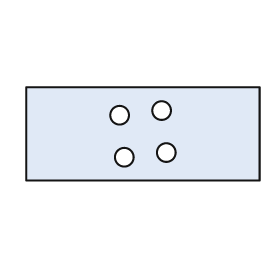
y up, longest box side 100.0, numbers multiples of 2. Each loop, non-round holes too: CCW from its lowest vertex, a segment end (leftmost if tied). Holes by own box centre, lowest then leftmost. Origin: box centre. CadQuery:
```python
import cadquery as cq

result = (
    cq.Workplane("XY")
    .moveTo(-50.0, -20.0)
    .lineTo(50.0, -20.0)
    .lineTo(50.0, 20.0)
    .lineTo(-50.0, 20.0)
    .close()
    .moveTo(-8.0, -10.0)
    .circle(4.0)
    .moveTo(10.0, -8.0)
    .circle(4.0)
    .moveTo(-10.0, 8.0)
    .circle(4.0)
    .moveTo(8.0, 10.0)
    .circle(4.0)
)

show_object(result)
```